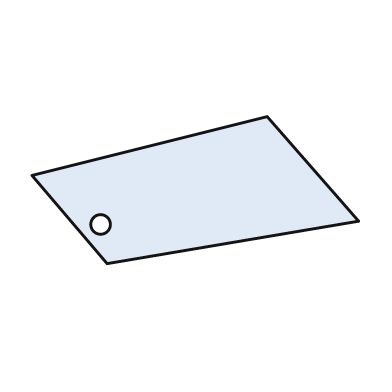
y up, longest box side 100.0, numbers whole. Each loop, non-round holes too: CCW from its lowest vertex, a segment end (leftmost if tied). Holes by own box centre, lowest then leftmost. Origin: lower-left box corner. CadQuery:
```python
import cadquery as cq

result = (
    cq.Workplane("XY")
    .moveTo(23.0, 0.0)
    .lineTo(100.0, 13.0)
    .lineTo(72.0, 45.0)
    .lineTo(0.0, 27.0)
    .close()
    .moveTo(21.0, 12.0)
    .circle(3.0)
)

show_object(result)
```